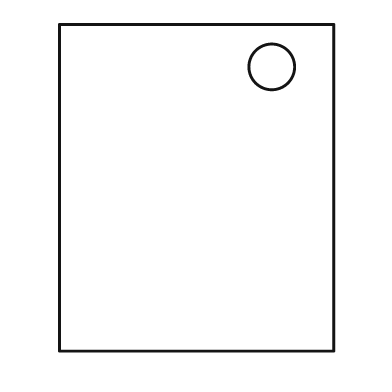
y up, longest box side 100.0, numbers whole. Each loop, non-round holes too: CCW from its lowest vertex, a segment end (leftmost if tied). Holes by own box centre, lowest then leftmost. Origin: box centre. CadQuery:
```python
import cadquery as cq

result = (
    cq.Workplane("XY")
    .moveTo(-42.0, -50.0)
    .lineTo(42.0, -50.0)
    .lineTo(42.0, 50.0)
    .lineTo(-42.0, 50.0)
    .close()
    .moveTo(23.0, 37.0)
    .circle(7.0)
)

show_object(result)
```